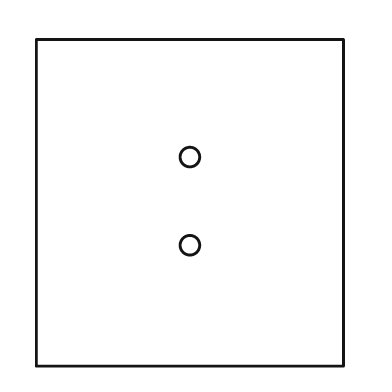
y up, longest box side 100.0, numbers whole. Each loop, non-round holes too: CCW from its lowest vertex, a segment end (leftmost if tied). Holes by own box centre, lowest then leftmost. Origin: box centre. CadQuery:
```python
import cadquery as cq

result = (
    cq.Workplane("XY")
    .moveTo(-47.0, -50.0)
    .lineTo(47.0, -50.0)
    .lineTo(47.0, 50.0)
    .lineTo(-47.0, 50.0)
    .close()
    .moveTo(0.0, -13.0)
    .circle(3.0)
    .moveTo(0.0, 14.0)
    .circle(3.0)
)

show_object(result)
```